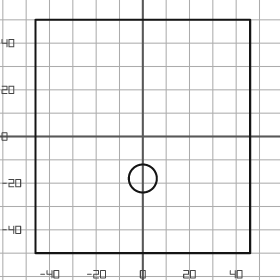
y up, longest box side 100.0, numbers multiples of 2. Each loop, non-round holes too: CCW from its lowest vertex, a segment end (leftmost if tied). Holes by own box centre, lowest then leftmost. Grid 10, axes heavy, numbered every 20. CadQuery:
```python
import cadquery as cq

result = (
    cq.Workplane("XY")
    .moveTo(-46.0, -50.0)
    .lineTo(46.0, -50.0)
    .lineTo(46.0, 50.0)
    .lineTo(-46.0, 50.0)
    .close()
    .moveTo(0.0, -18.0)
    .circle(6.0)
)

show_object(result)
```